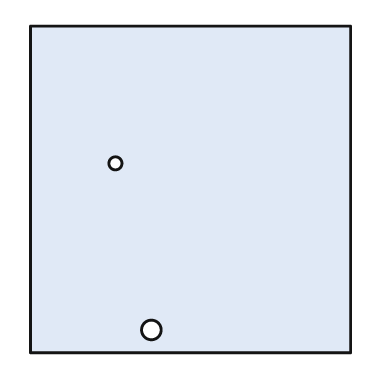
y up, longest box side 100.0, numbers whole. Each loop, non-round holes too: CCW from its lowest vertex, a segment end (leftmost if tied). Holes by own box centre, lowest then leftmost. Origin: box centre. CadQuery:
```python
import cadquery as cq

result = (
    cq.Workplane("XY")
    .moveTo(-49.0, -50.0)
    .lineTo(49.0, -50.0)
    .lineTo(49.0, 50.0)
    .lineTo(-49.0, 50.0)
    .close()
    .moveTo(-12.0, -43.0)
    .circle(3.0)
    .moveTo(-23.0, 8.0)
    .circle(2.0)
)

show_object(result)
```